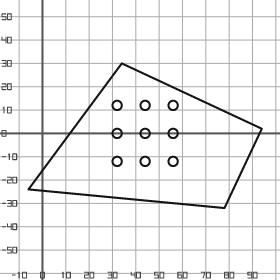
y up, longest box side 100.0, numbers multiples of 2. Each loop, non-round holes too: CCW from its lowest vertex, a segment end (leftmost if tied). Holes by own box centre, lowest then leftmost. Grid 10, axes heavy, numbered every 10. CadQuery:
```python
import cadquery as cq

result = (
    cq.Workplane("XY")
    .moveTo(78.0, -32.0)
    .lineTo(94.0, 2.0)
    .lineTo(34.0, 30.0)
    .lineTo(-6.0, -24.0)
    .close()
    .moveTo(32.0, -12.0)
    .circle(2.0)
    .moveTo(44.0, -12.0)
    .circle(2.0)
    .moveTo(56.0, -12.0)
    .circle(2.0)
    .moveTo(32.0, 0.0)
    .circle(2.0)
    .moveTo(44.0, 0.0)
    .circle(2.0)
    .moveTo(56.0, 0.0)
    .circle(2.0)
    .moveTo(32.0, 12.0)
    .circle(2.0)
    .moveTo(44.0, 12.0)
    .circle(2.0)
    .moveTo(56.0, 12.0)
    .circle(2.0)
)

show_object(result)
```